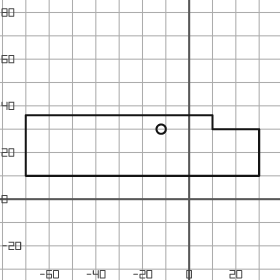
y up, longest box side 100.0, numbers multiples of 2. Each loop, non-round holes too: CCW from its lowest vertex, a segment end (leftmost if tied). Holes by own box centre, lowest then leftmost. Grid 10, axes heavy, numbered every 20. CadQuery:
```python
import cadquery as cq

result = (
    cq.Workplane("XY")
    .moveTo(-70.0, 10.0)
    .lineTo(30.0, 10.0)
    .lineTo(30.0, 30.0)
    .lineTo(10.0, 30.0)
    .lineTo(10.0, 36.0)
    .lineTo(-70.0, 36.0)
    .close()
    .moveTo(-12.0, 30.0)
    .circle(2.0)
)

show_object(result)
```